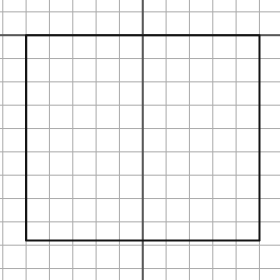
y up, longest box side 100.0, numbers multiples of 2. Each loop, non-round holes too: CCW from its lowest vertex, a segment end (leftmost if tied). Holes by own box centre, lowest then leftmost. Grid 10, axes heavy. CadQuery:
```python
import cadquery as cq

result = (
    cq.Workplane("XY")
    .moveTo(-50.0, -88.0)
    .lineTo(50.0, -88.0)
    .lineTo(50.0, 0.0)
    .lineTo(-50.0, 0.0)
    .close()
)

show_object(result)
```